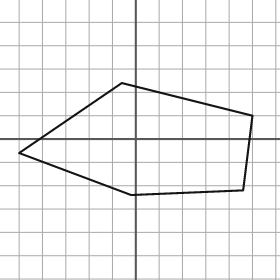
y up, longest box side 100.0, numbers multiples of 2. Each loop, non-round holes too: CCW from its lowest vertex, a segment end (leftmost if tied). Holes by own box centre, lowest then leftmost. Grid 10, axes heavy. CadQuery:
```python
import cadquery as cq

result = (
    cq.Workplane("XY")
    .moveTo(-2.0, -24.0)
    .lineTo(46.0, -22.0)
    .lineTo(50.0, 10.0)
    .lineTo(-6.0, 24.0)
    .lineTo(-50.0, -6.0)
    .close()
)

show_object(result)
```